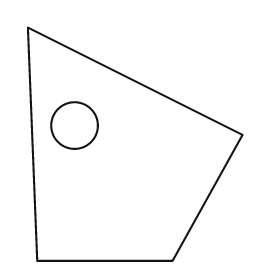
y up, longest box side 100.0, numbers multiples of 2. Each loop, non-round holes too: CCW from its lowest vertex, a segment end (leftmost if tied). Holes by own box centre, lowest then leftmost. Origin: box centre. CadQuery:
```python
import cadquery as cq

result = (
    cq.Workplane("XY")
    .moveTo(-42.0, -50.0)
    .lineTo(16.0, -50.0)
    .lineTo(46.0, 4.0)
    .lineTo(-46.0, 50.0)
    .close()
    .moveTo(-26.0, 8.0)
    .circle(10.0)
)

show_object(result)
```